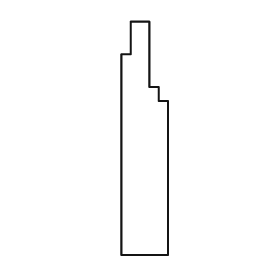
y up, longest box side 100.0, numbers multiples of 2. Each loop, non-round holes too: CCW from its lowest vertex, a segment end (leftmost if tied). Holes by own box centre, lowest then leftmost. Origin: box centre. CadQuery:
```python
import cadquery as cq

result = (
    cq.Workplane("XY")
    .moveTo(-10.0, -50.0)
    .lineTo(10.0, -50.0)
    .lineTo(10.0, 16.0)
    .lineTo(6.0, 16.0)
    .lineTo(6.0, 22.0)
    .lineTo(2.0, 22.0)
    .lineTo(2.0, 50.0)
    .lineTo(-6.0, 50.0)
    .lineTo(-6.0, 36.0)
    .lineTo(-10.0, 36.0)
    .close()
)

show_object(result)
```